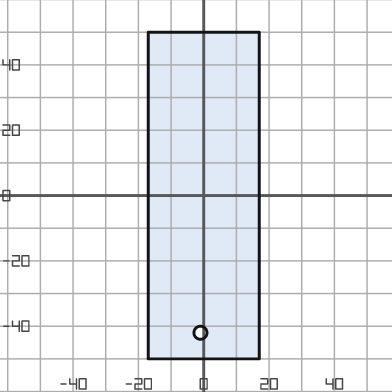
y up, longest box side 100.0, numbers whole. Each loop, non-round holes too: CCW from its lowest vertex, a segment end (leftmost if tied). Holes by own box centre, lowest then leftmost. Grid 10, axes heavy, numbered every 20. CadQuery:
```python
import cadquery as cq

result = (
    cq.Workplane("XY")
    .moveTo(-17.0, -50.0)
    .lineTo(17.0, -50.0)
    .lineTo(17.0, 50.0)
    .lineTo(-17.0, 50.0)
    .close()
    .moveTo(-1.0, -42.0)
    .circle(2.0)
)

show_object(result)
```